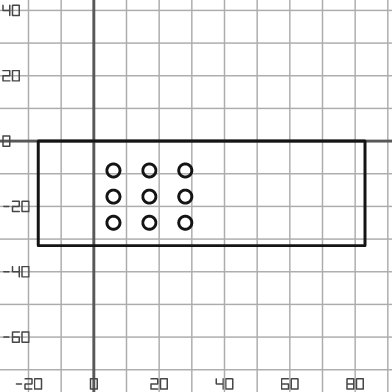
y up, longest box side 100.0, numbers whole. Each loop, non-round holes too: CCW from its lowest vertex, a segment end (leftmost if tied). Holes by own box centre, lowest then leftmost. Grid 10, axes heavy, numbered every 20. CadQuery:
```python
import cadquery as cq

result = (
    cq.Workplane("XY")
    .moveTo(-17.0, -32.0)
    .lineTo(83.0, -32.0)
    .lineTo(83.0, 0.0)
    .lineTo(-17.0, 0.0)
    .close()
    .moveTo(6.0, -25.0)
    .circle(2.0)
    .moveTo(17.0, -25.0)
    .circle(2.0)
    .moveTo(28.0, -25.0)
    .circle(2.0)
    .moveTo(6.0, -17.0)
    .circle(2.0)
    .moveTo(17.0, -17.0)
    .circle(2.0)
    .moveTo(28.0, -17.0)
    .circle(2.0)
    .moveTo(6.0, -9.0)
    .circle(2.0)
    .moveTo(17.0, -9.0)
    .circle(2.0)
    .moveTo(28.0, -9.0)
    .circle(2.0)
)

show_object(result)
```